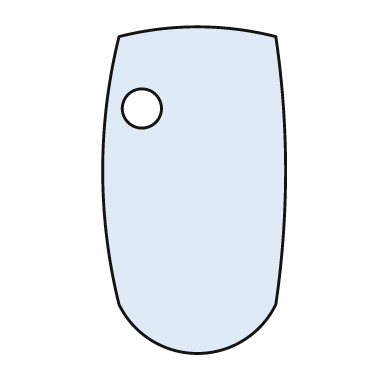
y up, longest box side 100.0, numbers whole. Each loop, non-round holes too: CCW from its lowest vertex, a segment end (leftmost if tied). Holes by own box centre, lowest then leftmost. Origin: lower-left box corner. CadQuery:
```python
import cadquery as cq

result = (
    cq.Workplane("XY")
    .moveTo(5.0, 15.0)
    .threePointArc((29.0, 0.0), (53.0, 15.0))
    .threePointArc((56.0, 56.0), (53.0, 97.0))
    .threePointArc((29.0, 100.0), (5.0, 97.0))
    .threePointArc((0.0, 56.0), (5.0, 15.0))
    .close()
    .moveTo(12.0, 75.0)
    .circle(6.0)
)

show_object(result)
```